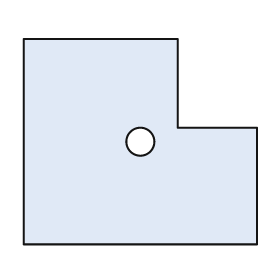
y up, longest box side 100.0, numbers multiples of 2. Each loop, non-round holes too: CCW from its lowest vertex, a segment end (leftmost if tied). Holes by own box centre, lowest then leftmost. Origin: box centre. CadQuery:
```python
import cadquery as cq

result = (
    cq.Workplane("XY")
    .moveTo(-50.0, -44.0)
    .lineTo(50.0, -44.0)
    .lineTo(50.0, 6.0)
    .lineTo(16.0, 6.0)
    .lineTo(16.0, 44.0)
    .lineTo(-50.0, 44.0)
    .close()
    .moveTo(0.0, 0.0)
    .circle(6.0)
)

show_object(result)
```